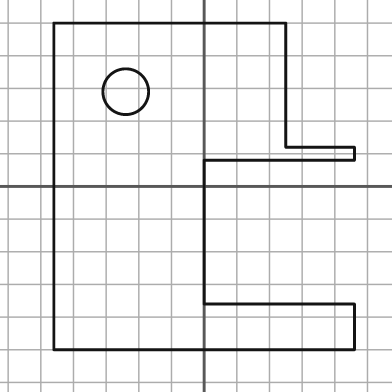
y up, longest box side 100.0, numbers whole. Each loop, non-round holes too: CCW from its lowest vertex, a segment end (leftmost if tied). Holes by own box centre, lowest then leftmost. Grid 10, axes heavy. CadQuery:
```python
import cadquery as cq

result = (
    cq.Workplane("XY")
    .moveTo(-46.0, -50.0)
    .lineTo(46.0, -50.0)
    .lineTo(46.0, -36.0)
    .lineTo(0.0, -36.0)
    .lineTo(0.0, 8.0)
    .lineTo(46.0, 8.0)
    .lineTo(46.0, 12.0)
    .lineTo(25.0, 12.0)
    .lineTo(25.0, 50.0)
    .lineTo(-46.0, 50.0)
    .close()
    .moveTo(-24.0, 29.0)
    .circle(7.0)
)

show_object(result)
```